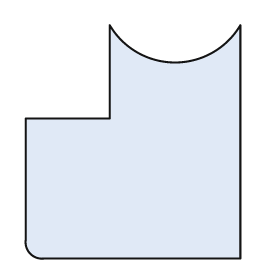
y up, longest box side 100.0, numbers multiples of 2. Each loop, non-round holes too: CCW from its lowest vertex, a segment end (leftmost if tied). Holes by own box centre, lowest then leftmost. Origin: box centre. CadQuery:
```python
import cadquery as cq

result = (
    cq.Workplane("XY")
    .moveTo(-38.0, -50.0)
    .lineTo(46.0, -50.0)
    .lineTo(46.0, 50.0)
    .threePointArc((18.0, 34.0), (-10.0, 50.0))
    .lineTo(-10.0, 10.0)
    .lineTo(-46.0, 10.0)
    .lineTo(-46.0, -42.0)
    .threePointArc((-44.0, -48.0), (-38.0, -50.0))
    .close()
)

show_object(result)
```